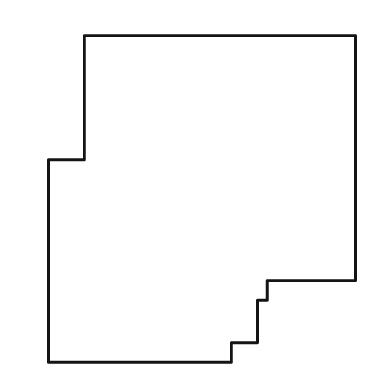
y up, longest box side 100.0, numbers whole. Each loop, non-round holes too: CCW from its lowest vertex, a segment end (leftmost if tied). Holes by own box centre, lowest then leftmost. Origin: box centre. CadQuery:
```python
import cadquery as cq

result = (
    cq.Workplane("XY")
    .moveTo(-47.0, -50.0)
    .lineTo(9.0, -50.0)
    .lineTo(9.0, -44.0)
    .lineTo(17.0, -44.0)
    .lineTo(17.0, -31.0)
    .lineTo(20.0, -31.0)
    .lineTo(20.0, -25.0)
    .lineTo(47.0, -25.0)
    .lineTo(47.0, 50.0)
    .lineTo(-36.0, 50.0)
    .lineTo(-36.0, 12.0)
    .lineTo(-47.0, 12.0)
    .close()
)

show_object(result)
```